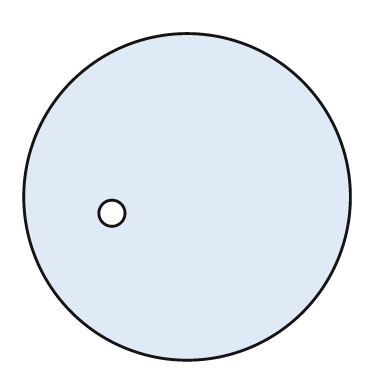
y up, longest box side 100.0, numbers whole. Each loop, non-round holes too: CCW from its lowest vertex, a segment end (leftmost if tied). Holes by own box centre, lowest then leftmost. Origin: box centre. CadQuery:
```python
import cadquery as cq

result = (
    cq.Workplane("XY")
    .moveTo(0.0, 0.0)
    .circle(50.0)
    .moveTo(-23.0, -5.0)
    .circle(4.0)
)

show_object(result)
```